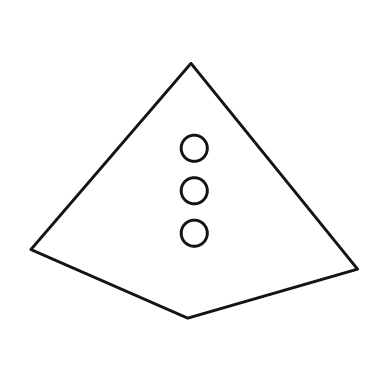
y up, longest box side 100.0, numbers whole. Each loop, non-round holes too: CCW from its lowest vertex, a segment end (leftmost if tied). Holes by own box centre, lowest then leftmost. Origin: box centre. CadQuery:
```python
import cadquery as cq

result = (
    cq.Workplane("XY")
    .moveTo(-2.0, -39.0)
    .lineTo(50.0, -24.0)
    .lineTo(-1.0, 39.0)
    .lineTo(-50.0, -18.0)
    .close()
    .moveTo(0.0, -13.0)
    .circle(4.0)
    .moveTo(0.0, 0.0)
    .circle(4.0)
    .moveTo(0.0, 13.0)
    .circle(4.0)
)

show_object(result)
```